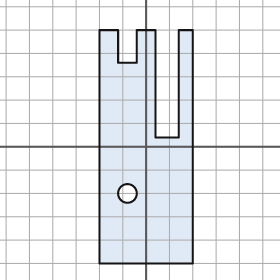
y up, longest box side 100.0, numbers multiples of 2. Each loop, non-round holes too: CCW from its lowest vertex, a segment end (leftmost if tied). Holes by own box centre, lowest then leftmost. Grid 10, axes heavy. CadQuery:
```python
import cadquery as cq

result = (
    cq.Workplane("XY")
    .moveTo(-20.0, -50.0)
    .lineTo(20.0, -50.0)
    .lineTo(20.0, 50.0)
    .lineTo(14.0, 50.0)
    .lineTo(14.0, 4.0)
    .lineTo(4.0, 4.0)
    .lineTo(4.0, 50.0)
    .lineTo(-4.0, 50.0)
    .lineTo(-4.0, 36.0)
    .lineTo(-12.0, 36.0)
    .lineTo(-12.0, 50.0)
    .lineTo(-20.0, 50.0)
    .close()
    .moveTo(-8.0, -20.0)
    .circle(4.0)
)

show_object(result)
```